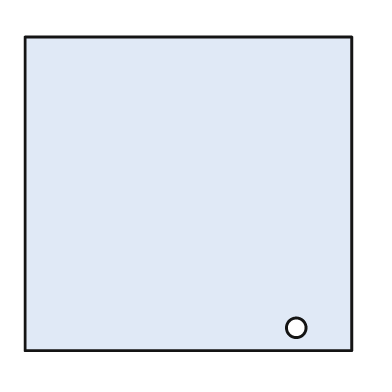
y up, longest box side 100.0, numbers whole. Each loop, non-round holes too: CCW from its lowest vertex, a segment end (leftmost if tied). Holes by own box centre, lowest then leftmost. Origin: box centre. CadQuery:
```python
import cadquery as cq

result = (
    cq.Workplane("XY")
    .moveTo(-50.0, -48.0)
    .lineTo(50.0, -48.0)
    .lineTo(50.0, 48.0)
    .lineTo(-50.0, 48.0)
    .close()
    .moveTo(33.0, -41.0)
    .circle(3.0)
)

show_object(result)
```